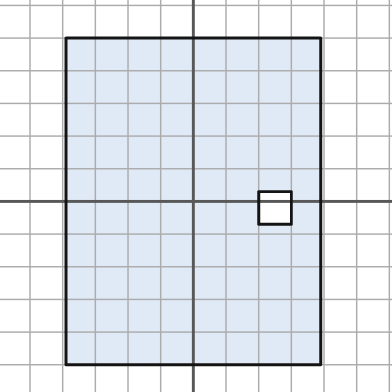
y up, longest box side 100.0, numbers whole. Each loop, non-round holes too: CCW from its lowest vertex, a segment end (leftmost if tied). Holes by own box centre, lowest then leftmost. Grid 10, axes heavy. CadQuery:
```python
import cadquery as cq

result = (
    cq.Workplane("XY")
    .moveTo(-39.0, -50.0)
    .lineTo(39.0, -50.0)
    .lineTo(39.0, 50.0)
    .lineTo(-39.0, 50.0)
    .close()
    .moveTo(20.0, -7.0)
    .lineTo(30.0, -7.0)
    .lineTo(30.0, 3.0)
    .lineTo(20.0, 3.0)
    .close()
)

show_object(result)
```